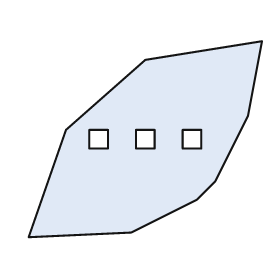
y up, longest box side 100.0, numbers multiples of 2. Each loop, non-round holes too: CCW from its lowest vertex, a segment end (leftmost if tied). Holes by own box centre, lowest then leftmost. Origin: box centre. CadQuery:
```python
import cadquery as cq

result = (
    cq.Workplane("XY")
    .moveTo(-50.0, -42.0)
    .lineTo(-6.0, -40.0)
    .lineTo(22.0, -26.0)
    .lineTo(30.0, -18.0)
    .lineTo(44.0, 10.0)
    .lineTo(50.0, 42.0)
    .lineTo(0.0, 34.0)
    .lineTo(-34.0, 4.0)
    .close()
    .moveTo(-24.0, -4.0)
    .lineTo(-16.0, -4.0)
    .lineTo(-16.0, 4.0)
    .lineTo(-24.0, 4.0)
    .close()
    .moveTo(-4.0, -4.0)
    .lineTo(4.0, -4.0)
    .lineTo(4.0, 4.0)
    .lineTo(-4.0, 4.0)
    .close()
    .moveTo(16.0, -4.0)
    .lineTo(24.0, -4.0)
    .lineTo(24.0, 4.0)
    .lineTo(16.0, 4.0)
    .close()
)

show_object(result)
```